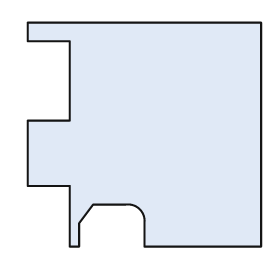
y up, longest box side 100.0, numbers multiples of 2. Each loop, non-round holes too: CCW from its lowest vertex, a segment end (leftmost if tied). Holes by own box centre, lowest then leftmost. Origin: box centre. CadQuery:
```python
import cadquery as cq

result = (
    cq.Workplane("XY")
    .moveTo(-32.0, -48.0)
    .lineTo(-28.0, -48.0)
    .lineTo(-28.0, -38.0)
    .lineTo(-22.0, -30.0)
    .lineTo(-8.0, -30.0)
    .threePointArc((-2.0, -32.0), (0.0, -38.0))
    .lineTo(0.0, -48.0)
    .lineTo(50.0, -48.0)
    .lineTo(50.0, 48.0)
    .lineTo(-50.0, 48.0)
    .lineTo(-50.0, 40.0)
    .lineTo(-32.0, 40.0)
    .lineTo(-32.0, 6.0)
    .lineTo(-50.0, 6.0)
    .lineTo(-50.0, -22.0)
    .lineTo(-32.0, -22.0)
    .close()
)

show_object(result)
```